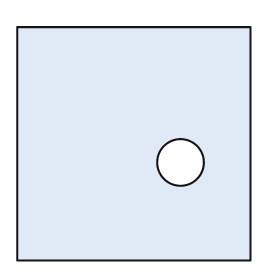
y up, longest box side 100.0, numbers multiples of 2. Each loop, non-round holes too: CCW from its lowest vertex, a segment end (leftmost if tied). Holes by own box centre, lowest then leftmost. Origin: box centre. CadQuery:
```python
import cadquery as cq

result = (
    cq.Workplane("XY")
    .moveTo(-50.0, -50.0)
    .lineTo(50.0, -50.0)
    .lineTo(50.0, 50.0)
    .lineTo(-50.0, 50.0)
    .close()
    .moveTo(20.0, -8.0)
    .circle(10.0)
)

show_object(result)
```